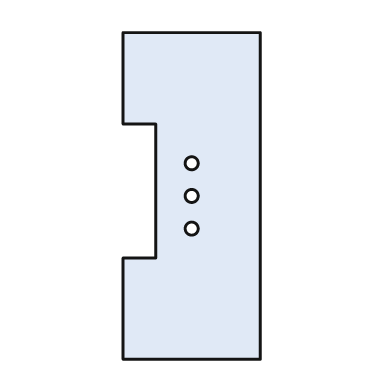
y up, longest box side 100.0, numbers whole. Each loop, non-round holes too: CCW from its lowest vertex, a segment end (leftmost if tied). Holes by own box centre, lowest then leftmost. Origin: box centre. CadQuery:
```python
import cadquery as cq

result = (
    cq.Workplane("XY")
    .moveTo(-21.0, -50.0)
    .lineTo(21.0, -50.0)
    .lineTo(21.0, 50.0)
    .lineTo(-21.0, 50.0)
    .lineTo(-21.0, 22.0)
    .lineTo(-11.0, 22.0)
    .lineTo(-11.0, -19.0)
    .lineTo(-21.0, -19.0)
    .close()
    .moveTo(0.0, -10.0)
    .circle(2.0)
    .moveTo(0.0, 0.0)
    .circle(2.0)
    .moveTo(0.0, 10.0)
    .circle(2.0)
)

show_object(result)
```